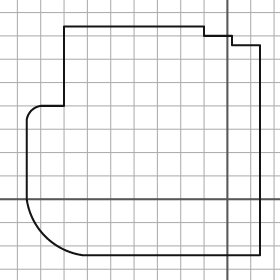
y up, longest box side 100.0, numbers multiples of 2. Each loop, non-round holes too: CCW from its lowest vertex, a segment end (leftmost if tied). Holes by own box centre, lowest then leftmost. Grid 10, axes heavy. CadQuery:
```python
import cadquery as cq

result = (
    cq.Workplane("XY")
    .moveTo(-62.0, -24.0)
    .lineTo(14.0, -24.0)
    .lineTo(14.0, 66.0)
    .lineTo(2.0, 66.0)
    .lineTo(2.0, 70.0)
    .lineTo(-10.0, 70.0)
    .lineTo(-10.0, 74.0)
    .lineTo(-70.0, 74.0)
    .lineTo(-70.0, 40.0)
    .lineTo(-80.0, 40.0)
    .threePointArc((-84.0, 38.0), (-86.0, 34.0))
    .lineTo(-86.0, 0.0)
    .threePointArc((-78.0, -16.0), (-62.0, -24.0))
    .close()
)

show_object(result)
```